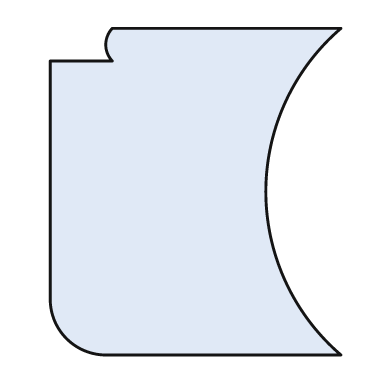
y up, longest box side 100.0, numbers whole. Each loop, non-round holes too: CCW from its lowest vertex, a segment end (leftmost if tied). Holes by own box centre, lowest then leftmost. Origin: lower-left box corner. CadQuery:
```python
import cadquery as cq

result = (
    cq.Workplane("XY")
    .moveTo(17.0, 0.0)
    .lineTo(89.0, 0.0)
    .threePointArc((66.0, 50.0), (89.0, 100.0))
    .lineTo(19.0, 100.0)
    .threePointArc((17.0, 95.0), (19.0, 90.0))
    .lineTo(0.0, 90.0)
    .lineTo(0.0, 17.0)
    .threePointArc((5.0, 5.0), (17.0, 0.0))
    .close()
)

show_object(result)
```